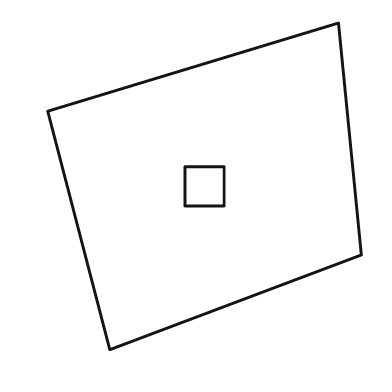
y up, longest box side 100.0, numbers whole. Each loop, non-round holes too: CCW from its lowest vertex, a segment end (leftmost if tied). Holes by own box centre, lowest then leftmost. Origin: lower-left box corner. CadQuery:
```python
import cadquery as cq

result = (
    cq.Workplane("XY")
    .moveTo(19.0, 0.0)
    .lineTo(96.0, 29.0)
    .lineTo(89.0, 100.0)
    .lineTo(0.0, 73.0)
    .close()
    .moveTo(42.0, 44.0)
    .lineTo(54.0, 44.0)
    .lineTo(54.0, 56.0)
    .lineTo(42.0, 56.0)
    .close()
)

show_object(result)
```